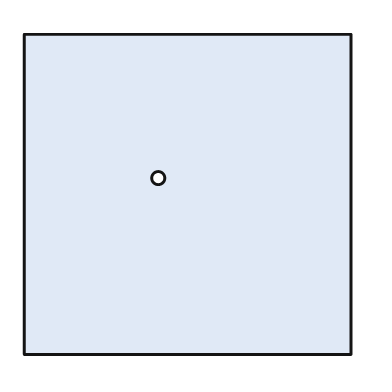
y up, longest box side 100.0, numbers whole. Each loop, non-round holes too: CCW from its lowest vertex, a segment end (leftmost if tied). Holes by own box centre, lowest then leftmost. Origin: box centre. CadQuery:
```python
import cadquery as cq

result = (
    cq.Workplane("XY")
    .moveTo(-50.0, -49.0)
    .lineTo(50.0, -49.0)
    .lineTo(50.0, 49.0)
    .lineTo(-50.0, 49.0)
    .close()
    .moveTo(-9.0, 5.0)
    .circle(2.0)
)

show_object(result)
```